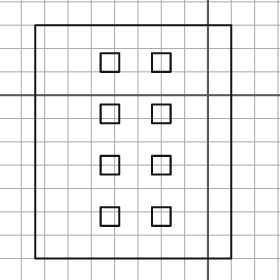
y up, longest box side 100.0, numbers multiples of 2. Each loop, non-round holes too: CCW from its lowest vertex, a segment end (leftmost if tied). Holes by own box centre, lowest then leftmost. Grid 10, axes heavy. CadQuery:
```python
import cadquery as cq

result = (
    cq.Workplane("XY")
    .moveTo(-74.0, -70.0)
    .lineTo(10.0, -70.0)
    .lineTo(10.0, 30.0)
    .lineTo(-74.0, 30.0)
    .close()
    .moveTo(-46.0, -56.0)
    .lineTo(-38.0, -56.0)
    .lineTo(-38.0, -48.0)
    .lineTo(-46.0, -48.0)
    .close()
    .moveTo(-24.0, -56.0)
    .lineTo(-16.0, -56.0)
    .lineTo(-16.0, -48.0)
    .lineTo(-24.0, -48.0)
    .close()
    .moveTo(-46.0, -34.0)
    .lineTo(-38.0, -34.0)
    .lineTo(-38.0, -26.0)
    .lineTo(-46.0, -26.0)
    .close()
    .moveTo(-24.0, -34.0)
    .lineTo(-16.0, -34.0)
    .lineTo(-16.0, -26.0)
    .lineTo(-24.0, -26.0)
    .close()
    .moveTo(-46.0, -12.0)
    .lineTo(-38.0, -12.0)
    .lineTo(-38.0, -4.0)
    .lineTo(-46.0, -4.0)
    .close()
    .moveTo(-24.0, -12.0)
    .lineTo(-16.0, -12.0)
    .lineTo(-16.0, -4.0)
    .lineTo(-24.0, -4.0)
    .close()
    .moveTo(-46.0, 10.0)
    .lineTo(-38.0, 10.0)
    .lineTo(-38.0, 18.0)
    .lineTo(-46.0, 18.0)
    .close()
    .moveTo(-24.0, 10.0)
    .lineTo(-16.0, 10.0)
    .lineTo(-16.0, 18.0)
    .lineTo(-24.0, 18.0)
    .close()
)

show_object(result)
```